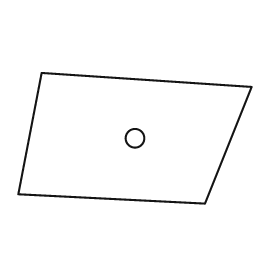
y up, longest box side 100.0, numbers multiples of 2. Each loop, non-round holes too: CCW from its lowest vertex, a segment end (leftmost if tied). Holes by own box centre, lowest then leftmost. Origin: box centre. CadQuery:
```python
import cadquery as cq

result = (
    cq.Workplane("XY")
    .moveTo(30.0, -28.0)
    .lineTo(50.0, 22.0)
    .lineTo(-40.0, 28.0)
    .lineTo(-50.0, -24.0)
    .close()
    .moveTo(0.0, 0.0)
    .circle(4.0)
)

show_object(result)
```